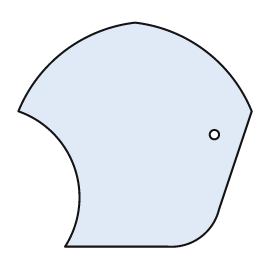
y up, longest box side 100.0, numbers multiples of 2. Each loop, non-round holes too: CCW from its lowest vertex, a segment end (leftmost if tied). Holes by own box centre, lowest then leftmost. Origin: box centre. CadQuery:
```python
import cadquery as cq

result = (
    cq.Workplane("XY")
    .moveTo(-30.0, -48.0)
    .lineTo(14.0, -48.0)
    .threePointArc((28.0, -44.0), (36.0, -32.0))
    .lineTo(50.0, 10.0)
    .threePointArc((30.0, 36.0), (0.0, 48.0))
    .threePointArc((-30.0, 36.0), (-50.0, 10.0))
    .threePointArc((-26.0, -14.0), (-30.0, -48.0))
    .close()
    .moveTo(34.0, 0.0)
    .circle(2.0)
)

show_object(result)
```